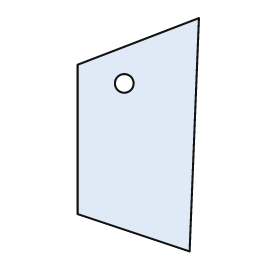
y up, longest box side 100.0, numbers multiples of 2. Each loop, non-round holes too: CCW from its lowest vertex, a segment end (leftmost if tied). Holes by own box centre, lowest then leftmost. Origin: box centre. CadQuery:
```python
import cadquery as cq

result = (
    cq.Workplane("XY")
    .moveTo(22.0, -50.0)
    .lineTo(26.0, 50.0)
    .lineTo(-26.0, 30.0)
    .lineTo(-26.0, -34.0)
    .close()
    .moveTo(-6.0, 22.0)
    .circle(4.0)
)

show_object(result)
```